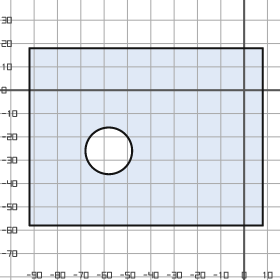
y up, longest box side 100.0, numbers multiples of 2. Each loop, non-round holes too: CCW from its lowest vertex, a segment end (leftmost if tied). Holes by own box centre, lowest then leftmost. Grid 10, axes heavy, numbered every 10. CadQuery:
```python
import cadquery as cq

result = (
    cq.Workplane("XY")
    .moveTo(-92.0, -58.0)
    .lineTo(8.0, -58.0)
    .lineTo(8.0, 18.0)
    .lineTo(-92.0, 18.0)
    .close()
    .moveTo(-58.0, -26.0)
    .circle(10.0)
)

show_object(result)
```